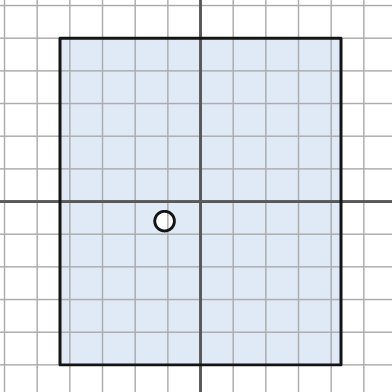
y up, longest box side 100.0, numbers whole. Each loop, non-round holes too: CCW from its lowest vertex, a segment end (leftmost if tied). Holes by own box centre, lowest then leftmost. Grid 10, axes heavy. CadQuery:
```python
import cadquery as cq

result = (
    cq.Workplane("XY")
    .moveTo(-43.0, -50.0)
    .lineTo(43.0, -50.0)
    .lineTo(43.0, 50.0)
    .lineTo(-43.0, 50.0)
    .close()
    .moveTo(-11.0, -6.0)
    .circle(3.0)
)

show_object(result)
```